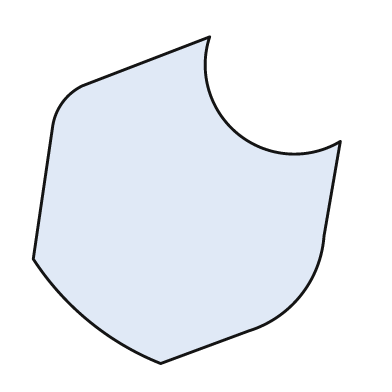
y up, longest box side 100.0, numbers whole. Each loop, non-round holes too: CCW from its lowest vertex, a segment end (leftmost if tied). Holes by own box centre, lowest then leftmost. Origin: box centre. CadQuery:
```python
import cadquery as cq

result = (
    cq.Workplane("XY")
    .moveTo(-8.0, -50.0)
    .lineTo(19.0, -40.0)
    .threePointArc((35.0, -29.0), (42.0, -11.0))
    .lineTo(47.0, 18.0)
    .threePointArc((16.0, 20.0), (7.0, 50.0))
    .lineTo(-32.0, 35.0)
    .threePointArc((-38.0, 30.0), (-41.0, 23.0))
    .lineTo(-47.0, -18.0)
    .threePointArc((-30.0, -37.0), (-8.0, -50.0))
    .close()
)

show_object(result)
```